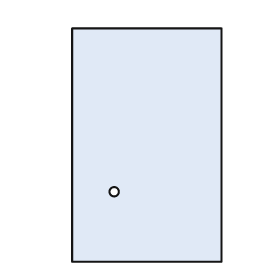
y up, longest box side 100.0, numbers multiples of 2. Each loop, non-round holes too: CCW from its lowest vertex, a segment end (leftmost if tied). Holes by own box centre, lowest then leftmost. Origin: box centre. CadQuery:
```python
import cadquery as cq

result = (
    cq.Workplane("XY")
    .moveTo(-32.0, -50.0)
    .lineTo(32.0, -50.0)
    .lineTo(32.0, 50.0)
    .lineTo(-32.0, 50.0)
    .close()
    .moveTo(-14.0, -20.0)
    .circle(2.0)
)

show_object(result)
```